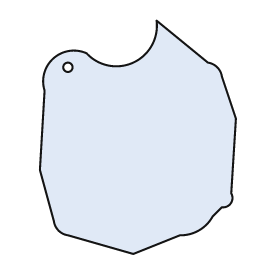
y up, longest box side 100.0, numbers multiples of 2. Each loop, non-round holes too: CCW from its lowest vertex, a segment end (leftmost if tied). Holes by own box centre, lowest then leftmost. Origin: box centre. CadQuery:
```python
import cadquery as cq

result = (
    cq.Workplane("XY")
    .moveTo(-2.0, -50.0)
    .lineTo(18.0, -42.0)
    .threePointArc((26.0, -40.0), (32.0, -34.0))
    .lineTo(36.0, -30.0)
    .threePointArc((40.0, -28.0), (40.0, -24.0))
    .lineTo(42.0, 8.0)
    .lineTo(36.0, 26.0)
    .threePointArc((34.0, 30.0), (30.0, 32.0))
    .lineTo(8.0, 50.0)
    .threePointArc((-2.0, 32.0), (-22.0, 36.0))
    .threePointArc((-36.0, 34.0), (-40.0, 20.0))
    .lineTo(-42.0, -14.0)
    .lineTo(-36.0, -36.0)
    .threePointArc((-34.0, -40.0), (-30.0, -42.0))
    .close()
    .moveTo(-30.0, 30.0)
    .circle(2.0)
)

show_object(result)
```